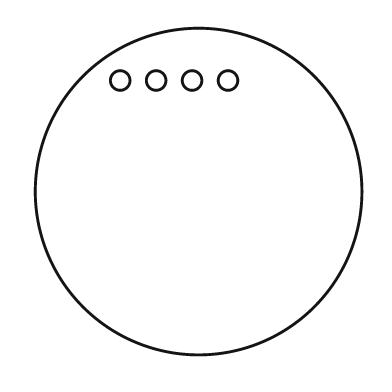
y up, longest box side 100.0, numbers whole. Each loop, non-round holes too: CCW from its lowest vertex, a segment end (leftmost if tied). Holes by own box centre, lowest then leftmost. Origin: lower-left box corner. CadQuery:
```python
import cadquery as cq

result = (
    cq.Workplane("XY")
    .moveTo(50.0, 50.0)
    .circle(50.0)
    .moveTo(26.0, 84.0)
    .circle(3.0)
    .moveTo(37.0, 84.0)
    .circle(3.0)
    .moveTo(48.0, 84.0)
    .circle(3.0)
    .moveTo(59.0, 84.0)
    .circle(3.0)
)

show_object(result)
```